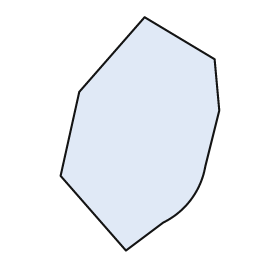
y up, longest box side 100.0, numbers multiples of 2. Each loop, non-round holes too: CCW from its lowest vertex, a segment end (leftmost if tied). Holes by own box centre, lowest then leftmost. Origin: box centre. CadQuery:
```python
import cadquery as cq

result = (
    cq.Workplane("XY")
    .moveTo(-6.0, -50.0)
    .lineTo(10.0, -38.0)
    .threePointArc((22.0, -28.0), (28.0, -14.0))
    .lineTo(34.0, 10.0)
    .lineTo(32.0, 32.0)
    .lineTo(2.0, 50.0)
    .lineTo(-26.0, 18.0)
    .lineTo(-34.0, -18.0)
    .close()
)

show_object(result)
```